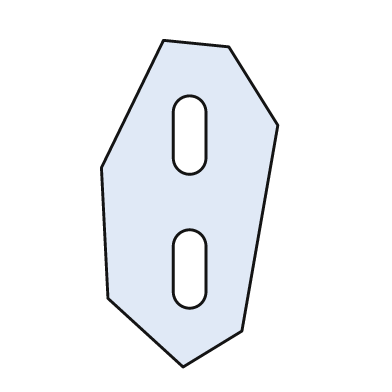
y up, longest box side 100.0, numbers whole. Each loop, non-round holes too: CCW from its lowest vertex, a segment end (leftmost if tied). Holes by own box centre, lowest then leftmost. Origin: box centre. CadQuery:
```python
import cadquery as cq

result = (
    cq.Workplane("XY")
    .moveTo(-2.0, -50.0)
    .lineTo(16.0, -39.0)
    .lineTo(27.0, 24.0)
    .lineTo(12.0, 48.0)
    .lineTo(-8.0, 50.0)
    .lineTo(-27.0, 11.0)
    .lineTo(-25.0, -29.0)
    .close()
    .moveTo(-5.0, -27.0)
    .threePointArc((0.0, -32.0), (5.0, -27.0))
    .lineTo(5.0, -13.0)
    .threePointArc((0.0, -8.0), (-5.0, -13.0))
    .close()
    .moveTo(-5.0, 14.0)
    .threePointArc((0.0, 9.0), (5.0, 14.0))
    .lineTo(5.0, 28.0)
    .threePointArc((0.0, 33.0), (-5.0, 28.0))
    .close()
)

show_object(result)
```